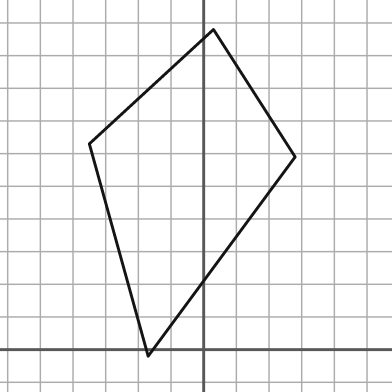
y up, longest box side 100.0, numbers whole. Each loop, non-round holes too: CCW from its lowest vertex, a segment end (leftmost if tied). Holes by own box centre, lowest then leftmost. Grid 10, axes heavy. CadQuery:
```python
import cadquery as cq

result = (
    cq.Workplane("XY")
    .moveTo(-17.0, -2.0)
    .lineTo(28.0, 59.0)
    .lineTo(3.0, 98.0)
    .lineTo(-35.0, 63.0)
    .close()
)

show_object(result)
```